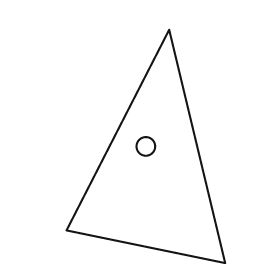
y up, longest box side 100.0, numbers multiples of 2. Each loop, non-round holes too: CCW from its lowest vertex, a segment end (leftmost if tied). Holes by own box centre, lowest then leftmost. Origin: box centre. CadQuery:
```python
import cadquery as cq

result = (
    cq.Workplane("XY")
    .moveTo(34.0, -50.0)
    .lineTo(10.0, 50.0)
    .lineTo(-34.0, -36.0)
    .close()
    .moveTo(0.0, 0.0)
    .circle(4.0)
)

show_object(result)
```